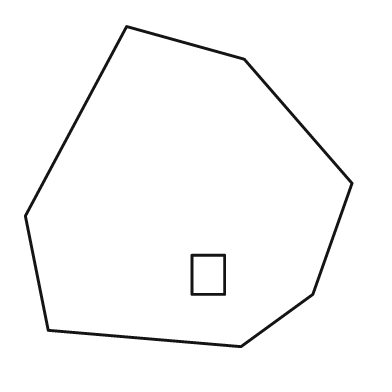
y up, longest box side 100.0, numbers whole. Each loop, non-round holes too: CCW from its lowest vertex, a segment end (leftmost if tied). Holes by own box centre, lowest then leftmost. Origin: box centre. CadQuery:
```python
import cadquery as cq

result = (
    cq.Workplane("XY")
    .moveTo(16.0, -49.0)
    .lineTo(38.0, -33.0)
    .lineTo(50.0, 1.0)
    .lineTo(17.0, 39.0)
    .lineTo(-19.0, 49.0)
    .lineTo(-50.0, -9.0)
    .lineTo(-43.0, -44.0)
    .close()
    .moveTo(1.0, -33.0)
    .lineTo(11.0, -33.0)
    .lineTo(11.0, -21.0)
    .lineTo(1.0, -21.0)
    .close()
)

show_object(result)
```